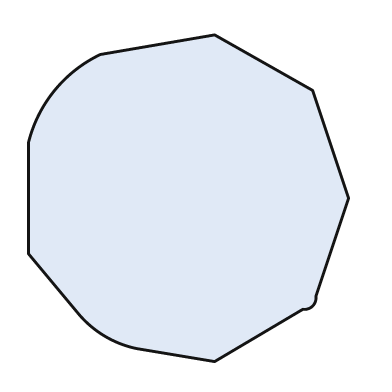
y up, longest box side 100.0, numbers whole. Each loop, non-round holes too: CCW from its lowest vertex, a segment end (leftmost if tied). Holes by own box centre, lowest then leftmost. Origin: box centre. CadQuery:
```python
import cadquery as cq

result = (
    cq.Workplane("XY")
    .moveTo(8.0, -50.0)
    .lineTo(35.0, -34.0)
    .threePointArc((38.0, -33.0), (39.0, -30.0))
    .lineTo(49.0, 0.0)
    .lineTo(38.0, 33.0)
    .lineTo(8.0, 50.0)
    .lineTo(-27.0, 44.0)
    .threePointArc((-41.0, 33.0), (-49.0, 17.0))
    .lineTo(-49.0, -17.0)
    .lineTo(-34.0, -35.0)
    .threePointArc((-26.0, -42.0), (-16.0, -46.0))
    .close()
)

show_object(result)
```